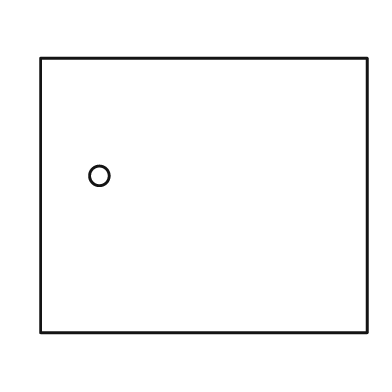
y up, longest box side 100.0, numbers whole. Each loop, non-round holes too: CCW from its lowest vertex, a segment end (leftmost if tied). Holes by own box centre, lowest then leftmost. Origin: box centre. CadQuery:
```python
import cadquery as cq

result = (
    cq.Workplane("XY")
    .moveTo(-50.0, -42.0)
    .lineTo(50.0, -42.0)
    .lineTo(50.0, 42.0)
    .lineTo(-50.0, 42.0)
    .close()
    .moveTo(-32.0, 6.0)
    .circle(3.0)
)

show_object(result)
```